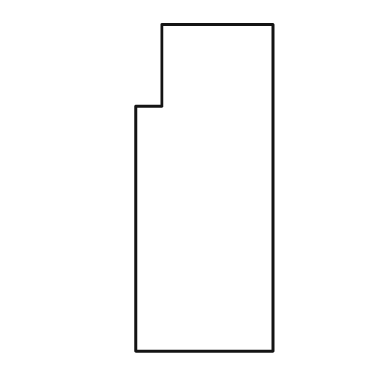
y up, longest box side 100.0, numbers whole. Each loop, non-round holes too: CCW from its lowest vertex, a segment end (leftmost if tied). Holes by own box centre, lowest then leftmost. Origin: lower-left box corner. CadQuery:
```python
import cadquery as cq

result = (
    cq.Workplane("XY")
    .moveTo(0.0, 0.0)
    .lineTo(42.0, 0.0)
    .lineTo(42.0, 100.0)
    .lineTo(8.0, 100.0)
    .lineTo(8.0, 75.0)
    .lineTo(0.0, 75.0)
    .close()
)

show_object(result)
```